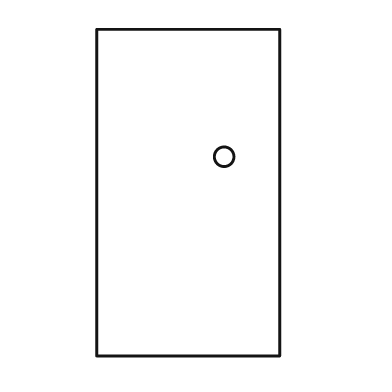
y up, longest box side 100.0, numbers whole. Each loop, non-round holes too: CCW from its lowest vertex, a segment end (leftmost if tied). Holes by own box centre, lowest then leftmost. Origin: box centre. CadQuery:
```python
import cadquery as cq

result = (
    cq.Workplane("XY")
    .moveTo(-28.0, -50.0)
    .lineTo(28.0, -50.0)
    .lineTo(28.0, 50.0)
    .lineTo(-28.0, 50.0)
    .close()
    .moveTo(11.0, 11.0)
    .circle(3.0)
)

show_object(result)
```